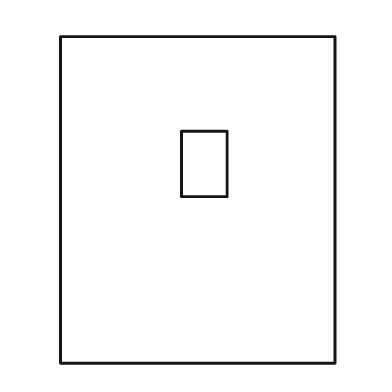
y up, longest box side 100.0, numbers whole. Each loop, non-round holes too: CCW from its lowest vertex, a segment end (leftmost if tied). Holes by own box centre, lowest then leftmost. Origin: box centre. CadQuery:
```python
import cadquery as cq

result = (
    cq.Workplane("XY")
    .moveTo(-42.0, -50.0)
    .lineTo(42.0, -50.0)
    .lineTo(42.0, 50.0)
    .lineTo(-42.0, 50.0)
    .close()
    .moveTo(-5.0, 1.0)
    .lineTo(9.0, 1.0)
    .lineTo(9.0, 21.0)
    .lineTo(-5.0, 21.0)
    .close()
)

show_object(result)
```